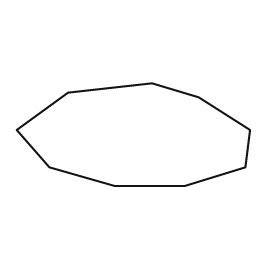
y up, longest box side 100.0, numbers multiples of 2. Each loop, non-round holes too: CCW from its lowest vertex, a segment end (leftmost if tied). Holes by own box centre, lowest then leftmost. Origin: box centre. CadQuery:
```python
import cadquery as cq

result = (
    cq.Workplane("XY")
    .moveTo(-8.0, -22.0)
    .lineTo(22.0, -22.0)
    .lineTo(48.0, -14.0)
    .lineTo(50.0, 2.0)
    .lineTo(28.0, 16.0)
    .lineTo(8.0, 22.0)
    .lineTo(-28.0, 18.0)
    .lineTo(-50.0, 2.0)
    .lineTo(-36.0, -14.0)
    .close()
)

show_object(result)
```